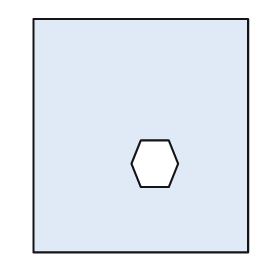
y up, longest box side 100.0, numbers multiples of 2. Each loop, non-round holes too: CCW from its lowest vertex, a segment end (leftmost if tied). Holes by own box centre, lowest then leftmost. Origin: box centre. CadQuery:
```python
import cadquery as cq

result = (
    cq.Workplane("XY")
    .moveTo(-46.0, -50.0)
    .lineTo(46.0, -50.0)
    .lineTo(46.0, 50.0)
    .lineTo(-46.0, 50.0)
    .close()
    .moveTo(0.0, -22.0)
    .lineTo(12.0, -22.0)
    .lineTo(16.0, -12.0)
    .lineTo(12.0, -2.0)
    .lineTo(0.0, -2.0)
    .lineTo(-4.0, -12.0)
    .close()
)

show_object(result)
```